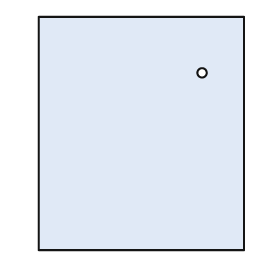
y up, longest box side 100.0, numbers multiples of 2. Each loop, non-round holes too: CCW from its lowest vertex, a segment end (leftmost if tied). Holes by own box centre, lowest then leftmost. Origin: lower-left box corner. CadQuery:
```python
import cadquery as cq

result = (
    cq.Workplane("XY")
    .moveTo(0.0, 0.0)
    .lineTo(88.0, 0.0)
    .lineTo(88.0, 100.0)
    .lineTo(0.0, 100.0)
    .close()
    .moveTo(70.0, 76.0)
    .circle(2.0)
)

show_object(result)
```